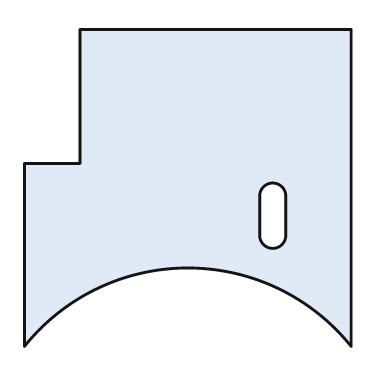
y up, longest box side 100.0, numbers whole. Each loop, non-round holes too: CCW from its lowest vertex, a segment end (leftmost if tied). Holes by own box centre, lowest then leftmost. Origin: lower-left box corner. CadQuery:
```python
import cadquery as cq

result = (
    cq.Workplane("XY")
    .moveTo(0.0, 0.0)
    .threePointArc((50.0, 24.0), (100.0, 0.0))
    .lineTo(100.0, 97.0)
    .lineTo(17.0, 97.0)
    .lineTo(17.0, 56.0)
    .lineTo(0.0, 56.0)
    .close()
    .moveTo(72.0, 34.0)
    .threePointArc((76.0, 30.0), (80.0, 34.0))
    .lineTo(80.0, 46.0)
    .threePointArc((76.0, 50.0), (72.0, 46.0))
    .close()
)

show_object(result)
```